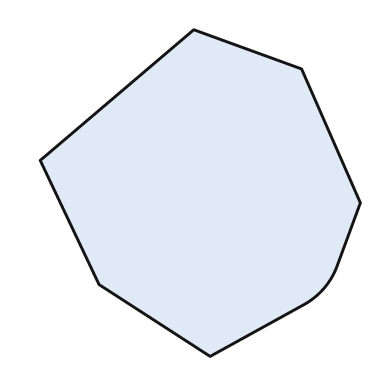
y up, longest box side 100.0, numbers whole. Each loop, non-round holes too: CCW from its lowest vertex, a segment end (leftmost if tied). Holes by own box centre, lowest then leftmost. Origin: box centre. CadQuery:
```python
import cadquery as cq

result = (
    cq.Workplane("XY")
    .moveTo(3.0, -50.0)
    .lineTo(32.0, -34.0)
    .threePointArc((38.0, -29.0), (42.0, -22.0))
    .lineTo(49.0, -3.0)
    .lineTo(31.0, 38.0)
    .lineTo(-2.0, 50.0)
    .lineTo(-49.0, 10.0)
    .lineTo(-31.0, -28.0)
    .close()
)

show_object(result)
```